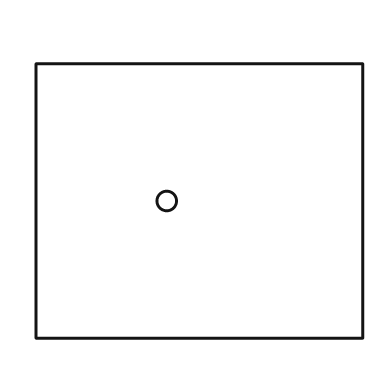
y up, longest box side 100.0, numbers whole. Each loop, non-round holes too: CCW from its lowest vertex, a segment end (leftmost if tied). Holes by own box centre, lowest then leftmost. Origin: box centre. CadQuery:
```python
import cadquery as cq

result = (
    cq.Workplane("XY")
    .moveTo(-50.0, -42.0)
    .lineTo(50.0, -42.0)
    .lineTo(50.0, 42.0)
    .lineTo(-50.0, 42.0)
    .close()
    .moveTo(-10.0, 0.0)
    .circle(3.0)
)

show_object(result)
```